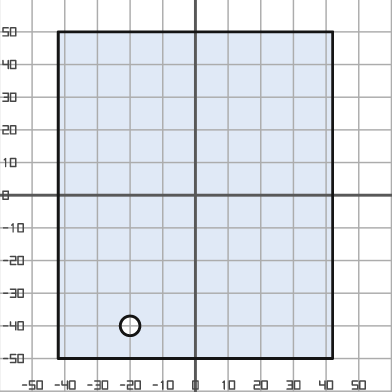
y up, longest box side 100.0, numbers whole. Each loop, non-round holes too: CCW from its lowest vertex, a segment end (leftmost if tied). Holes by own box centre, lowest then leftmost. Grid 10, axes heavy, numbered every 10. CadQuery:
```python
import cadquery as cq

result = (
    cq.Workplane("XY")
    .moveTo(-42.0, -50.0)
    .lineTo(42.0, -50.0)
    .lineTo(42.0, 50.0)
    .lineTo(-42.0, 50.0)
    .close()
    .moveTo(-20.0, -40.0)
    .circle(3.0)
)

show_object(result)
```